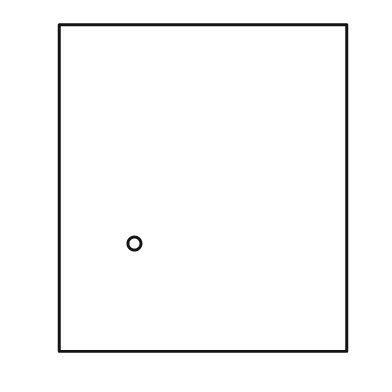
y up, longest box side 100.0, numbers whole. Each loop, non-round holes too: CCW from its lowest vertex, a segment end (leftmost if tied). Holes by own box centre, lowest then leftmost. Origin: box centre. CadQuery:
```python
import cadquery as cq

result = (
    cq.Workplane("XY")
    .moveTo(-44.0, -50.0)
    .lineTo(44.0, -50.0)
    .lineTo(44.0, 50.0)
    .lineTo(-44.0, 50.0)
    .close()
    .moveTo(-21.0, -17.0)
    .circle(2.0)
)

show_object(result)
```